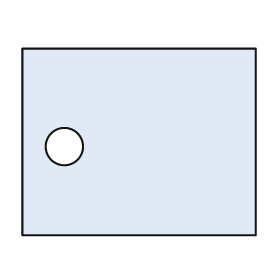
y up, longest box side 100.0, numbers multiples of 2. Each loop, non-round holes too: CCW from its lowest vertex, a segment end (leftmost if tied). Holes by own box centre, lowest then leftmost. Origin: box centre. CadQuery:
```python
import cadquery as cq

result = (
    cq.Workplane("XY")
    .moveTo(-50.0, -40.0)
    .lineTo(50.0, -40.0)
    .lineTo(50.0, 40.0)
    .lineTo(-50.0, 40.0)
    .close()
    .moveTo(-32.0, -2.0)
    .circle(8.0)
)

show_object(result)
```